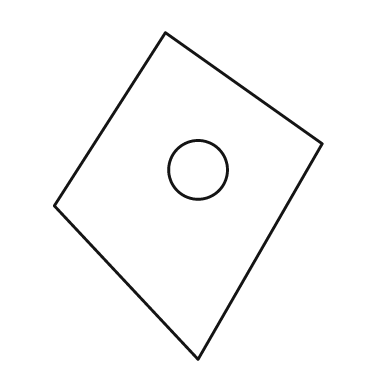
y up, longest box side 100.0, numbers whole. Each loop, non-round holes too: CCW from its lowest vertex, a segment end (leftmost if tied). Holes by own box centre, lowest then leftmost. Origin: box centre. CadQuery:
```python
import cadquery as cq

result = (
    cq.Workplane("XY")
    .moveTo(3.0, -50.0)
    .lineTo(41.0, 16.0)
    .lineTo(-7.0, 50.0)
    .lineTo(-41.0, -3.0)
    .close()
    .moveTo(3.0, 8.0)
    .circle(9.0)
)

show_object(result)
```